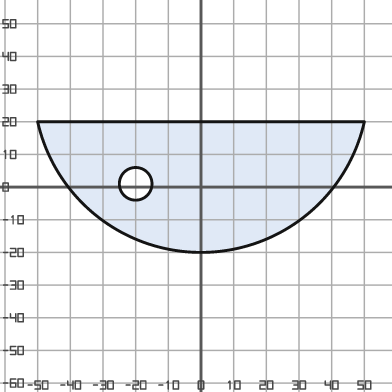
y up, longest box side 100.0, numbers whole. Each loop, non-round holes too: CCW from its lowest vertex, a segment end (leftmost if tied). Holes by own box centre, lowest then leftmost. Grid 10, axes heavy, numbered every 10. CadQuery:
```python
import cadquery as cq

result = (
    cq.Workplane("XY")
    .moveTo(-50.0, 20.0)
    .threePointArc((0.0, -20.0), (50.0, 20.0))
    .close()
    .moveTo(-20.0, 1.0)
    .circle(5.0)
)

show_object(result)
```